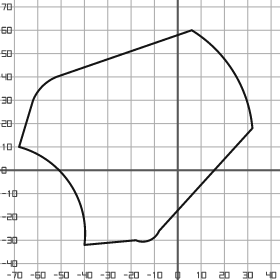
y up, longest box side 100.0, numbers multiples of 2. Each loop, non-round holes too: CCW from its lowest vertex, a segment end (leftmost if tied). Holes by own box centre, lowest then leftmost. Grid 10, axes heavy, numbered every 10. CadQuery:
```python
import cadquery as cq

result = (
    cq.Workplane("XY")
    .moveTo(-40.0, -32.0)
    .lineTo(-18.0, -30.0)
    .threePointArc((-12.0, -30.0), (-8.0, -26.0))
    .lineTo(32.0, 18.0)
    .threePointArc((24.0, 42.0), (6.0, 60.0))
    .lineTo(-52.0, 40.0)
    .threePointArc((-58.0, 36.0), (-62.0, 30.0))
    .lineTo(-68.0, 10.0)
    .threePointArc((-46.0, -6.0), (-40.0, -32.0))
    .close()
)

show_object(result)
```